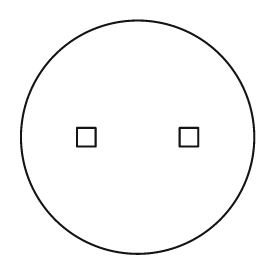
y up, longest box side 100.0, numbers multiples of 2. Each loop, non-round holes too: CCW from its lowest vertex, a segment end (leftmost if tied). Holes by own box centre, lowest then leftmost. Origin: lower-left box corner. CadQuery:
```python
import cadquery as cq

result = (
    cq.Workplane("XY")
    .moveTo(50.0, 50.0)
    .circle(50.0)
    .moveTo(24.0, 46.0)
    .lineTo(32.0, 46.0)
    .lineTo(32.0, 54.0)
    .lineTo(24.0, 54.0)
    .close()
    .moveTo(68.0, 46.0)
    .lineTo(76.0, 46.0)
    .lineTo(76.0, 54.0)
    .lineTo(68.0, 54.0)
    .close()
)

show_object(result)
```